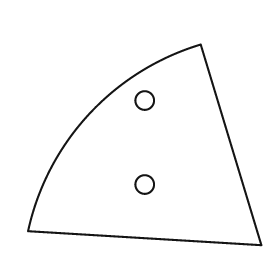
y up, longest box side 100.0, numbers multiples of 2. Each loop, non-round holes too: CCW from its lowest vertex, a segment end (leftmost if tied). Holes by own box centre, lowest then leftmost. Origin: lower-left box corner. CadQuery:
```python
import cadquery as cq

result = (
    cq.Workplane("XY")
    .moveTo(100.0, 0.0)
    .lineTo(74.0, 86.0)
    .threePointArc((26.0, 56.0), (0.0, 6.0))
    .close()
    .moveTo(50.0, 26.0)
    .circle(4.0)
    .moveTo(50.0, 62.0)
    .circle(4.0)
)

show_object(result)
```